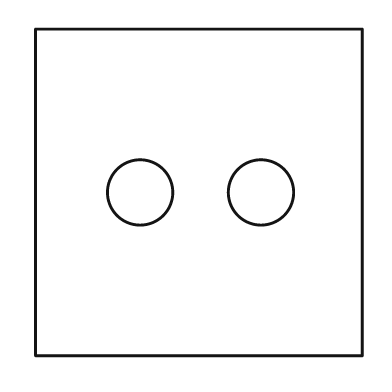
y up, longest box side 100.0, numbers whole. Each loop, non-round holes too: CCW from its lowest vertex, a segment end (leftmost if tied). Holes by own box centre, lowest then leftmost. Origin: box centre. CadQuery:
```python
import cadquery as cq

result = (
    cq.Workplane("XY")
    .moveTo(-50.0, -50.0)
    .lineTo(50.0, -50.0)
    .lineTo(50.0, 50.0)
    .lineTo(-50.0, 50.0)
    .close()
    .moveTo(-18.0, 0.0)
    .circle(10.0)
    .moveTo(19.0, 0.0)
    .circle(10.0)
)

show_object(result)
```